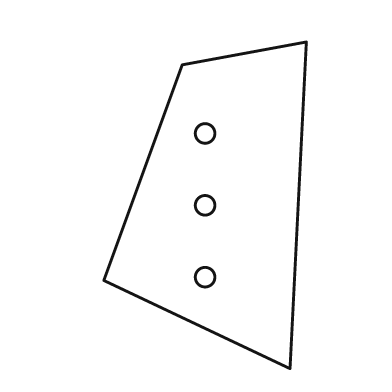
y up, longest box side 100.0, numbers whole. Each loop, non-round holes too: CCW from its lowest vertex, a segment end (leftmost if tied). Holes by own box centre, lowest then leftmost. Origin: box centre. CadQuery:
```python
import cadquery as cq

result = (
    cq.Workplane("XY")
    .moveTo(26.0, -50.0)
    .lineTo(31.0, 50.0)
    .lineTo(-7.0, 43.0)
    .lineTo(-31.0, -23.0)
    .close()
    .moveTo(0.0, -22.0)
    .circle(3.0)
    .moveTo(0.0, 0.0)
    .circle(3.0)
    .moveTo(0.0, 22.0)
    .circle(3.0)
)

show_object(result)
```